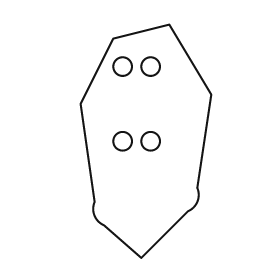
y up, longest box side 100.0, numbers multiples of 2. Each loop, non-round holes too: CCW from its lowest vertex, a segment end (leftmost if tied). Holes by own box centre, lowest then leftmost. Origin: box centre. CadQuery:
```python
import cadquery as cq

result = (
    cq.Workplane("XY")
    .moveTo(-2.0, -50.0)
    .lineTo(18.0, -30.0)
    .threePointArc((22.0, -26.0), (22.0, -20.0))
    .lineTo(28.0, 20.0)
    .lineTo(10.0, 50.0)
    .lineTo(-14.0, 44.0)
    .lineTo(-28.0, 16.0)
    .lineTo(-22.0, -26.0)
    .threePointArc((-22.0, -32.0), (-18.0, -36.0))
    .close()
    .moveTo(-10.0, 0.0)
    .circle(4.0)
    .moveTo(2.0, 0.0)
    .circle(4.0)
    .moveTo(-10.0, 32.0)
    .circle(4.0)
    .moveTo(2.0, 32.0)
    .circle(4.0)
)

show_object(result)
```